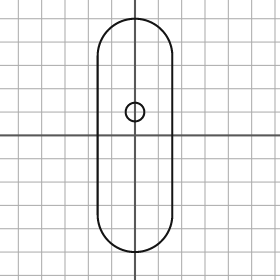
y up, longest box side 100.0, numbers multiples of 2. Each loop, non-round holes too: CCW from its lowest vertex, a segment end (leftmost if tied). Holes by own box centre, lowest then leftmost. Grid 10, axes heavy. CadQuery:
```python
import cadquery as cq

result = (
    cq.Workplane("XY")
    .moveTo(-16.0, -34.0)
    .threePointArc((0.0, -50.0), (16.0, -34.0))
    .lineTo(16.0, 34.0)
    .threePointArc((0.0, 50.0), (-16.0, 34.0))
    .close()
    .moveTo(0.0, 10.0)
    .circle(4.0)
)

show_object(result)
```